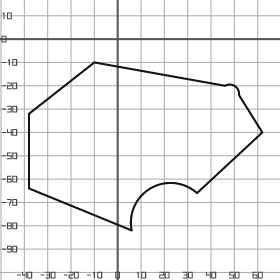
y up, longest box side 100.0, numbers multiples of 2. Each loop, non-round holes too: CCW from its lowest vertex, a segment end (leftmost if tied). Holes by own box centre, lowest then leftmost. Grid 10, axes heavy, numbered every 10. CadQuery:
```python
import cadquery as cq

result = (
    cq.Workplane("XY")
    .moveTo(6.0, -82.0)
    .threePointArc((14.0, -64.0), (34.0, -66.0))
    .lineTo(62.0, -40.0)
    .lineTo(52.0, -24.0)
    .threePointArc((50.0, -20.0), (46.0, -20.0))
    .lineTo(-10.0, -10.0)
    .lineTo(-38.0, -32.0)
    .lineTo(-38.0, -64.0)
    .close()
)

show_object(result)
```